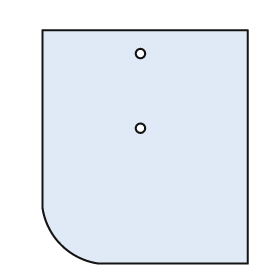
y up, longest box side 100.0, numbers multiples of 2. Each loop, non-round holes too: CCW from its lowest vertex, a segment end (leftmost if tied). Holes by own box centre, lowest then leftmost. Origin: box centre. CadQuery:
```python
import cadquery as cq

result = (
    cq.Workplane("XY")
    .moveTo(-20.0, -50.0)
    .lineTo(44.0, -50.0)
    .lineTo(44.0, 50.0)
    .lineTo(-44.0, 50.0)
    .lineTo(-44.0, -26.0)
    .threePointArc((-36.0, -42.0), (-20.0, -50.0))
    .close()
    .moveTo(-2.0, 8.0)
    .circle(2.0)
    .moveTo(-2.0, 40.0)
    .circle(2.0)
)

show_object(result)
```